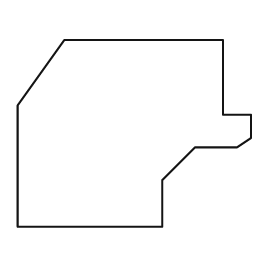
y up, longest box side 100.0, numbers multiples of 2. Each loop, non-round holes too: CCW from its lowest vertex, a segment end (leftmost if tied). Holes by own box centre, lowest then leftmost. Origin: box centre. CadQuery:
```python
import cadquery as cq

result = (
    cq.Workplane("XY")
    .moveTo(-50.0, -40.0)
    .lineTo(12.0, -40.0)
    .lineTo(12.0, -20.0)
    .lineTo(26.0, -6.0)
    .lineTo(44.0, -6.0)
    .lineTo(50.0, -2.0)
    .lineTo(50.0, 8.0)
    .lineTo(38.0, 8.0)
    .lineTo(38.0, 40.0)
    .lineTo(-30.0, 40.0)
    .lineTo(-50.0, 12.0)
    .close()
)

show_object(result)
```